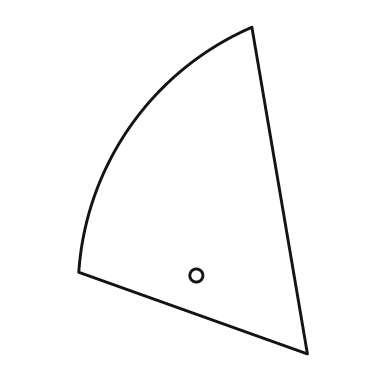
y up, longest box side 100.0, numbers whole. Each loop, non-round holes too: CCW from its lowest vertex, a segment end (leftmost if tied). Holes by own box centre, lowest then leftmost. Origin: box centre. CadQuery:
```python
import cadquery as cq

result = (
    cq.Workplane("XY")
    .moveTo(35.0, -50.0)
    .lineTo(18.0, 50.0)
    .threePointArc((-19.0, 20.0), (-35.0, -25.0))
    .close()
    .moveTo(1.0, -26.0)
    .circle(2.0)
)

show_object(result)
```